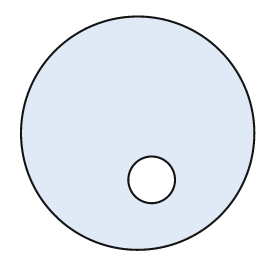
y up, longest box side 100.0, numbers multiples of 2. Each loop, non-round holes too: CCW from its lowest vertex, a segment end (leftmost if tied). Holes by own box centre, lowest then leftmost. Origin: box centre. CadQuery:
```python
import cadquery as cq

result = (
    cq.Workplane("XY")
    .moveTo(0.0, 0.0)
    .circle(50.0)
    .moveTo(6.0, -20.0)
    .circle(10.0)
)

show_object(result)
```